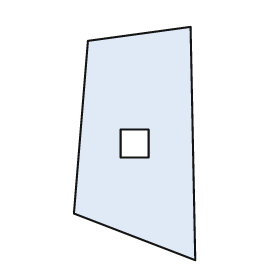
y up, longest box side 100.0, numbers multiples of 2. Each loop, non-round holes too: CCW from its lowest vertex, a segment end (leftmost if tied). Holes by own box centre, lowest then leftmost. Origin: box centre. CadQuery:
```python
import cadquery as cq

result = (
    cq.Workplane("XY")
    .moveTo(26.0, -50.0)
    .lineTo(24.0, 50.0)
    .lineTo(-20.0, 44.0)
    .lineTo(-26.0, -30.0)
    .close()
    .moveTo(-6.0, -6.0)
    .lineTo(6.0, -6.0)
    .lineTo(6.0, 6.0)
    .lineTo(-6.0, 6.0)
    .close()
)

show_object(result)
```